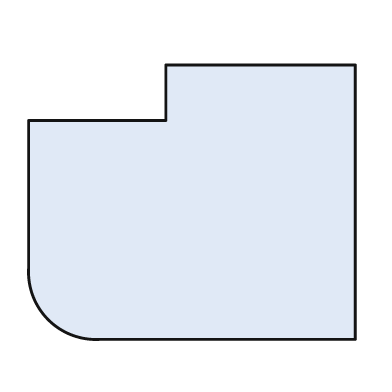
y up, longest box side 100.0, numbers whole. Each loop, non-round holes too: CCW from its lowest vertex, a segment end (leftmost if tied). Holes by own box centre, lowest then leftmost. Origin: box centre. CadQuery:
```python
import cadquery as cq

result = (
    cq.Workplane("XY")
    .moveTo(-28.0, -42.0)
    .lineTo(50.0, -42.0)
    .lineTo(50.0, 42.0)
    .lineTo(-8.0, 42.0)
    .lineTo(-8.0, 25.0)
    .lineTo(-50.0, 25.0)
    .lineTo(-50.0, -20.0)
    .threePointArc((-44.0, -36.0), (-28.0, -42.0))
    .close()
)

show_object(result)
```